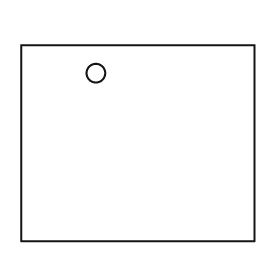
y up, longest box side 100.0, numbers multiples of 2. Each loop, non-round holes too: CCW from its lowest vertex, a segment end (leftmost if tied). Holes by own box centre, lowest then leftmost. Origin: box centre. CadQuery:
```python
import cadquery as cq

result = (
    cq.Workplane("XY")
    .moveTo(-50.0, -42.0)
    .lineTo(50.0, -42.0)
    .lineTo(50.0, 42.0)
    .lineTo(-50.0, 42.0)
    .close()
    .moveTo(-18.0, 30.0)
    .circle(4.0)
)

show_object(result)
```